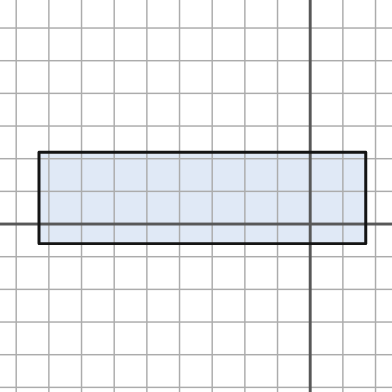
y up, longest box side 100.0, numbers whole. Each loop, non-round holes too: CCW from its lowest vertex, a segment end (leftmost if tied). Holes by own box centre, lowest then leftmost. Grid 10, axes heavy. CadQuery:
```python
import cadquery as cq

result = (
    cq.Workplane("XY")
    .moveTo(-83.0, -6.0)
    .lineTo(17.0, -6.0)
    .lineTo(17.0, 22.0)
    .lineTo(-83.0, 22.0)
    .close()
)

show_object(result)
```